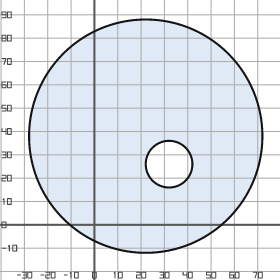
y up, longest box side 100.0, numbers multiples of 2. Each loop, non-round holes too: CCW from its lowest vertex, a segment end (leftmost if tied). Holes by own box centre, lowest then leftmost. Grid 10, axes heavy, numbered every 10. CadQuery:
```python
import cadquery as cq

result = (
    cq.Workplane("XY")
    .moveTo(22.0, 38.0)
    .circle(50.0)
    .moveTo(32.0, 26.0)
    .circle(10.0)
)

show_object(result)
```